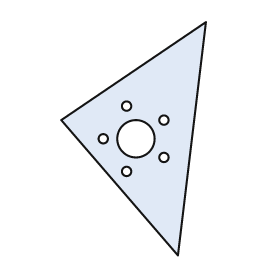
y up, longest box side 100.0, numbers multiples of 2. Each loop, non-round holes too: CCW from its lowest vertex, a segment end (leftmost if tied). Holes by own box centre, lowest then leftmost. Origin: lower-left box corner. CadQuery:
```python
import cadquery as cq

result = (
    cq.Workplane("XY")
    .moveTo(50.0, 0.0)
    .lineTo(62.0, 100.0)
    .lineTo(0.0, 58.0)
    .close()
    .moveTo(28.0, 36.0)
    .circle(2.0)
    .moveTo(44.0, 42.0)
    .circle(2.0)
    .moveTo(18.0, 50.0)
    .circle(2.0)
    .moveTo(32.0, 50.0)
    .circle(8.0)
    .moveTo(44.0, 58.0)
    .circle(2.0)
    .moveTo(28.0, 64.0)
    .circle(2.0)
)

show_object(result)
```